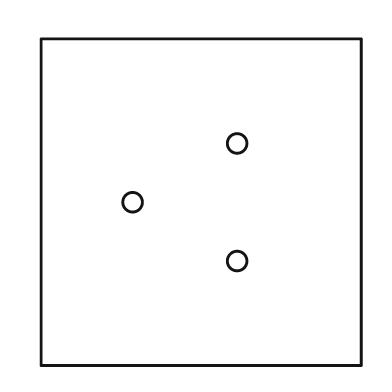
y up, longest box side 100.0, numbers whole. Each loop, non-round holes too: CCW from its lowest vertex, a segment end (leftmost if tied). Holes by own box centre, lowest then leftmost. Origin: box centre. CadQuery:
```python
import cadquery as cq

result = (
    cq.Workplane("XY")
    .moveTo(-49.0, -50.0)
    .lineTo(49.0, -50.0)
    .lineTo(49.0, 50.0)
    .lineTo(-49.0, 50.0)
    .close()
    .moveTo(11.0, -18.0)
    .circle(3.0)
    .moveTo(-21.0, 0.0)
    .circle(3.0)
    .moveTo(11.0, 18.0)
    .circle(3.0)
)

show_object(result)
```